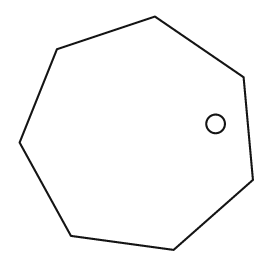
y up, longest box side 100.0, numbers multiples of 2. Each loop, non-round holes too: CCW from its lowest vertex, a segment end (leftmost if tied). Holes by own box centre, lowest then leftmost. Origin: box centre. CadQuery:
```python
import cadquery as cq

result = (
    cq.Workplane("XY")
    .moveTo(16.0, -50.0)
    .lineTo(50.0, -20.0)
    .lineTo(46.0, 24.0)
    .lineTo(8.0, 50.0)
    .lineTo(-34.0, 36.0)
    .lineTo(-50.0, -4.0)
    .lineTo(-28.0, -44.0)
    .close()
    .moveTo(34.0, 4.0)
    .circle(4.0)
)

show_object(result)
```